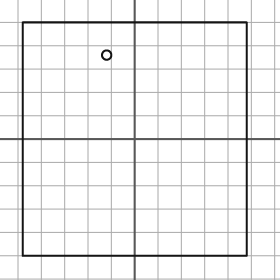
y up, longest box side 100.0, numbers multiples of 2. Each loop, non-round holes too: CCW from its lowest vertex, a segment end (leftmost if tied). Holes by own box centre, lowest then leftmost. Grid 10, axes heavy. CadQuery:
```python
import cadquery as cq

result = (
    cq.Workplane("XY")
    .moveTo(-48.0, -50.0)
    .lineTo(48.0, -50.0)
    .lineTo(48.0, 50.0)
    .lineTo(-48.0, 50.0)
    .close()
    .moveTo(-12.0, 36.0)
    .circle(2.0)
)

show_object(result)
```